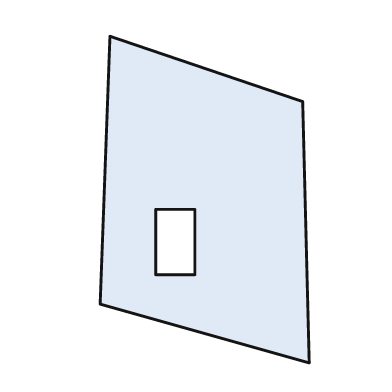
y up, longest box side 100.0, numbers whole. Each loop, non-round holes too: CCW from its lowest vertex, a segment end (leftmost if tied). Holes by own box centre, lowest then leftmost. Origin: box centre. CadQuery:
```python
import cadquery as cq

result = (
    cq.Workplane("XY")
    .moveTo(32.0, -50.0)
    .lineTo(30.0, 30.0)
    .lineTo(-29.0, 50.0)
    .lineTo(-32.0, -32.0)
    .close()
    .moveTo(-15.0, -23.0)
    .lineTo(-3.0, -23.0)
    .lineTo(-3.0, -3.0)
    .lineTo(-15.0, -3.0)
    .close()
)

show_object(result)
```